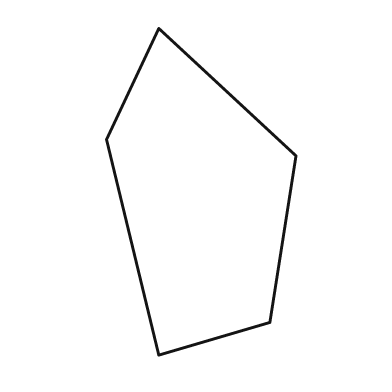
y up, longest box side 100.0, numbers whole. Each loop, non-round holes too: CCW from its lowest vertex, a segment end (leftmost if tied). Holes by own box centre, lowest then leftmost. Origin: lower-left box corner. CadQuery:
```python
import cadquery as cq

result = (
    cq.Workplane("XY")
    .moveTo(16.0, 0.0)
    .lineTo(50.0, 10.0)
    .lineTo(58.0, 61.0)
    .lineTo(16.0, 100.0)
    .lineTo(0.0, 66.0)
    .close()
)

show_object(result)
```